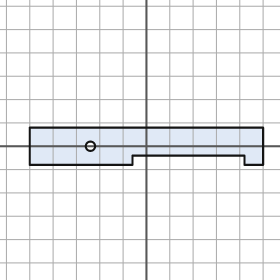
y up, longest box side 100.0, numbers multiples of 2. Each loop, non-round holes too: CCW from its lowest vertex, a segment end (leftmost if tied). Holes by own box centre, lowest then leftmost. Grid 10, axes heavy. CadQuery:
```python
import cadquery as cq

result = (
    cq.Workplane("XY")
    .moveTo(-50.0, -8.0)
    .lineTo(-6.0, -8.0)
    .lineTo(-6.0, -4.0)
    .lineTo(42.0, -4.0)
    .lineTo(42.0, -8.0)
    .lineTo(50.0, -8.0)
    .lineTo(50.0, 8.0)
    .lineTo(-50.0, 8.0)
    .close()
    .moveTo(-24.0, 0.0)
    .circle(2.0)
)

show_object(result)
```